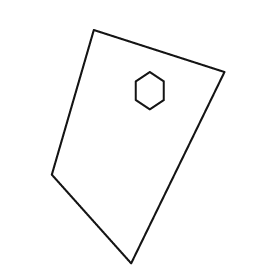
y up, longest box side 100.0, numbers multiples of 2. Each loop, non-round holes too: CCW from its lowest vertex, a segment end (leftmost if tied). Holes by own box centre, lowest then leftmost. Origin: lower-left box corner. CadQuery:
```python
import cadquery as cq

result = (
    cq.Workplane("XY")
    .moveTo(34.0, 0.0)
    .lineTo(74.0, 82.0)
    .lineTo(18.0, 100.0)
    .lineTo(0.0, 38.0)
    .close()
    .moveTo(42.0, 66.0)
    .lineTo(48.0, 70.0)
    .lineTo(48.0, 78.0)
    .lineTo(42.0, 82.0)
    .lineTo(36.0, 78.0)
    .lineTo(36.0, 70.0)
    .close()
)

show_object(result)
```